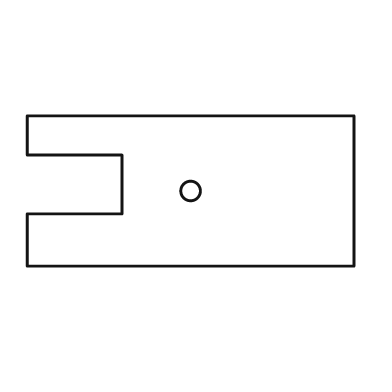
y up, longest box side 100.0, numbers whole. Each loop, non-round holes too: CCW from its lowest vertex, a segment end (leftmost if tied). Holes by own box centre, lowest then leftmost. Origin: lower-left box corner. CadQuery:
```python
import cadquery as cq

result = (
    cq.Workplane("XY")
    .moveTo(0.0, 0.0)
    .lineTo(100.0, 0.0)
    .lineTo(100.0, 46.0)
    .lineTo(0.0, 46.0)
    .lineTo(0.0, 34.0)
    .lineTo(29.0, 34.0)
    .lineTo(29.0, 16.0)
    .lineTo(0.0, 16.0)
    .close()
    .moveTo(50.0, 23.0)
    .circle(3.0)
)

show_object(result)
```